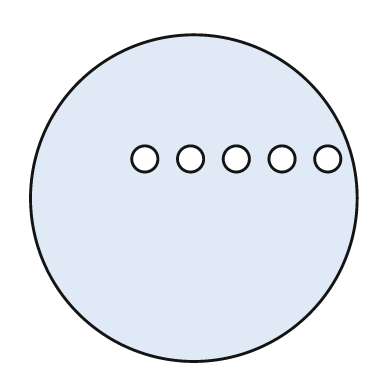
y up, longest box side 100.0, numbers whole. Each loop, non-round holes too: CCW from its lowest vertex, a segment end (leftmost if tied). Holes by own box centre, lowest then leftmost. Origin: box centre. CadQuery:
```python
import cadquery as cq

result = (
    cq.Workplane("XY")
    .moveTo(0.0, 0.0)
    .circle(50.0)
    .moveTo(-15.0, 12.0)
    .circle(4.0)
    .moveTo(-1.0, 12.0)
    .circle(4.0)
    .moveTo(13.0, 12.0)
    .circle(4.0)
    .moveTo(27.0, 12.0)
    .circle(4.0)
    .moveTo(41.0, 12.0)
    .circle(4.0)
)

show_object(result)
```